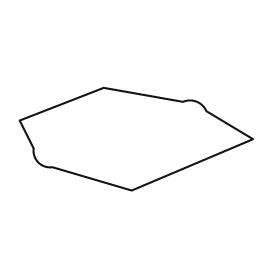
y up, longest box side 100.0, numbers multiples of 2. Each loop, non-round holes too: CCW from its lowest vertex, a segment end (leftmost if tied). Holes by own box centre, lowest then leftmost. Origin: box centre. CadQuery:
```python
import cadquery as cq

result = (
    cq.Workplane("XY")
    .moveTo(-2.0, -22.0)
    .lineTo(50.0, 0.0)
    .lineTo(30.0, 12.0)
    .threePointArc((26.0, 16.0), (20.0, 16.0))
    .lineTo(-14.0, 22.0)
    .lineTo(-50.0, 8.0)
    .lineTo(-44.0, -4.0)
    .threePointArc((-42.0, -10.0), (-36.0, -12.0))
    .close()
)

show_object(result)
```